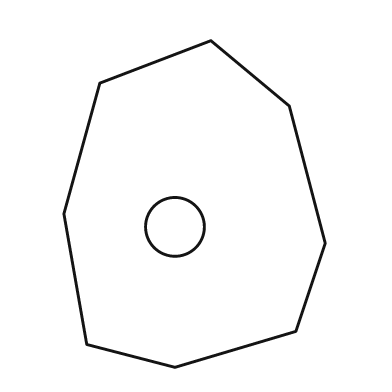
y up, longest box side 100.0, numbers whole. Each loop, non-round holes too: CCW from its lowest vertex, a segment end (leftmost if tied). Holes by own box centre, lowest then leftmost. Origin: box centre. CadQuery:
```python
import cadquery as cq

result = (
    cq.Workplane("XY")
    .moveTo(-6.0, -50.0)
    .lineTo(31.0, -39.0)
    .lineTo(40.0, -12.0)
    .lineTo(29.0, 30.0)
    .lineTo(5.0, 50.0)
    .lineTo(-29.0, 37.0)
    .lineTo(-40.0, -3.0)
    .lineTo(-33.0, -43.0)
    .close()
    .moveTo(-6.0, -7.0)
    .circle(9.0)
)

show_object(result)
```